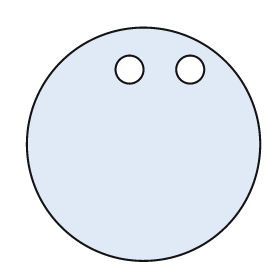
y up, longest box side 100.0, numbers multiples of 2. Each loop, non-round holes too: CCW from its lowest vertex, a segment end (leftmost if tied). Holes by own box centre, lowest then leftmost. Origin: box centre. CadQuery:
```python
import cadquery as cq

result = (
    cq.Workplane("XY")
    .moveTo(0.0, 0.0)
    .circle(50.0)
    .moveTo(-6.0, 32.0)
    .circle(6.0)
    .moveTo(20.0, 32.0)
    .circle(6.0)
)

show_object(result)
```